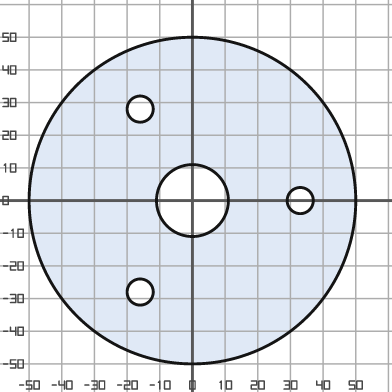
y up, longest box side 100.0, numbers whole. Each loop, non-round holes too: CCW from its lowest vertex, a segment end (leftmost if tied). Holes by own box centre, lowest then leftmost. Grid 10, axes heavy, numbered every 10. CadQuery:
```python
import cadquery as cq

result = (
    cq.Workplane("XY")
    .moveTo(0.0, 0.0)
    .circle(50.0)
    .moveTo(-16.0, -28.0)
    .circle(4.0)
    .moveTo(0.0, 0.0)
    .circle(11.0)
    .moveTo(33.0, 0.0)
    .circle(4.0)
    .moveTo(-16.0, 28.0)
    .circle(4.0)
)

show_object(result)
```